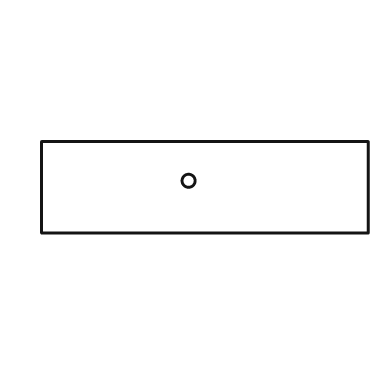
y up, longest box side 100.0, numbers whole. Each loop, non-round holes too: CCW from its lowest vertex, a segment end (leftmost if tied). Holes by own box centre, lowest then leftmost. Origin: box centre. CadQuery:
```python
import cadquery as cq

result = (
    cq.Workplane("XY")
    .moveTo(-50.0, -14.0)
    .lineTo(50.0, -14.0)
    .lineTo(50.0, 14.0)
    .lineTo(-50.0, 14.0)
    .close()
    .moveTo(-5.0, 2.0)
    .circle(2.0)
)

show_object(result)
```